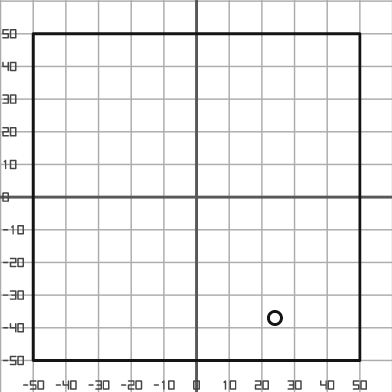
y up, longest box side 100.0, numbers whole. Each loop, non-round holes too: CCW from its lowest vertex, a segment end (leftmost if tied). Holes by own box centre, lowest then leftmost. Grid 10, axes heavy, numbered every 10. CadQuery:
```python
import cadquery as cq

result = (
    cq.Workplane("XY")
    .moveTo(-50.0, -50.0)
    .lineTo(50.0, -50.0)
    .lineTo(50.0, 50.0)
    .lineTo(-50.0, 50.0)
    .close()
    .moveTo(24.0, -37.0)
    .circle(2.0)
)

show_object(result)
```